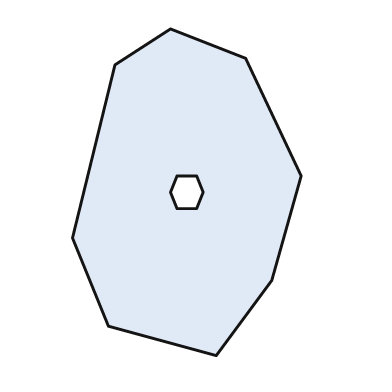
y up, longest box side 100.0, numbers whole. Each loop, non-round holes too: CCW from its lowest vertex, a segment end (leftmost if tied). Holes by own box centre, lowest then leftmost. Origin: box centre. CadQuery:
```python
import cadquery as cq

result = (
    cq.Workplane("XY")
    .moveTo(9.0, -50.0)
    .lineTo(26.0, -27.0)
    .lineTo(35.0, 5.0)
    .lineTo(18.0, 41.0)
    .lineTo(-5.0, 50.0)
    .lineTo(-22.0, 39.0)
    .lineTo(-35.0, -14.0)
    .lineTo(-24.0, -41.0)
    .close()
    .moveTo(-3.0, -5.0)
    .lineTo(3.0, -5.0)
    .lineTo(5.0, 0.0)
    .lineTo(3.0, 5.0)
    .lineTo(-3.0, 5.0)
    .lineTo(-5.0, 0.0)
    .close()
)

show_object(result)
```